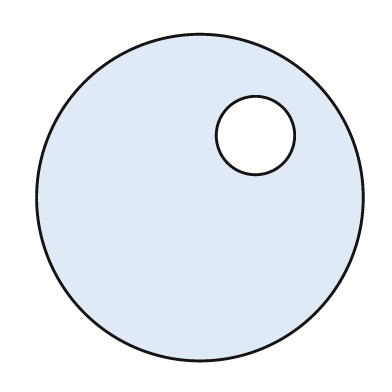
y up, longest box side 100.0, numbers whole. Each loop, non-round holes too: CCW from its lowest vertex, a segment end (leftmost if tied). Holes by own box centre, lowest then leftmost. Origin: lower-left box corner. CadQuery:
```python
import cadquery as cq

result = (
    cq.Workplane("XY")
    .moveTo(50.0, 50.0)
    .circle(50.0)
    .moveTo(67.0, 69.0)
    .circle(12.0)
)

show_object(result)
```